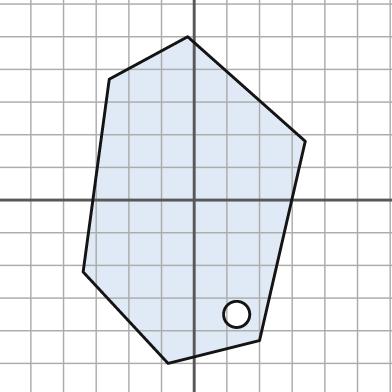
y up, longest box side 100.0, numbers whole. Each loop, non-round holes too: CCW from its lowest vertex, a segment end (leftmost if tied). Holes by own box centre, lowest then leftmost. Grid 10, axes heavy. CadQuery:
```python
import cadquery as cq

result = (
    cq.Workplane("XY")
    .moveTo(-8.0, -50.0)
    .lineTo(20.0, -43.0)
    .lineTo(34.0, 18.0)
    .lineTo(-2.0, 50.0)
    .lineTo(-26.0, 37.0)
    .lineTo(-34.0, -22.0)
    .close()
    .moveTo(13.0, -35.0)
    .circle(4.0)
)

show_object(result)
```